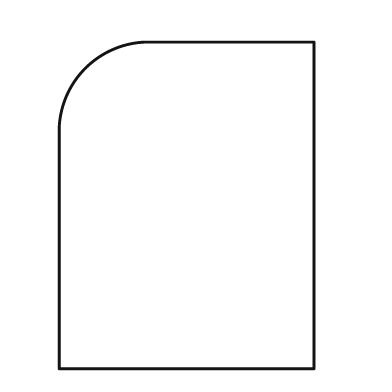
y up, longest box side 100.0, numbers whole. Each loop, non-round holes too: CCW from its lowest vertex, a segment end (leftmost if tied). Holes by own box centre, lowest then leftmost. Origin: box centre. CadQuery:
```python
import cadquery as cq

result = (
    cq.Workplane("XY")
    .moveTo(-39.0, -50.0)
    .lineTo(39.0, -50.0)
    .lineTo(39.0, 50.0)
    .lineTo(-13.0, 50.0)
    .threePointArc((-31.0, 42.0), (-39.0, 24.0))
    .close()
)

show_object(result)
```